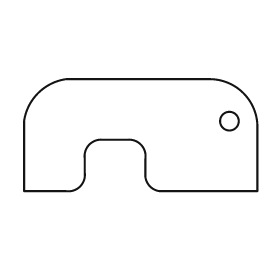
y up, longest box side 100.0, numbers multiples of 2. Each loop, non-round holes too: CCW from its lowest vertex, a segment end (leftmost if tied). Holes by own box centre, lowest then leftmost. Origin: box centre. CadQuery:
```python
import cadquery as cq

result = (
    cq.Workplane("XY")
    .moveTo(-50.0, -24.0)
    .lineTo(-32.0, -24.0)
    .threePointArc((-26.0, -22.0), (-24.0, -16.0))
    .lineTo(-24.0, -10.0)
    .threePointArc((-22.0, -4.0), (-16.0, -2.0))
    .lineTo(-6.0, -2.0)
    .threePointArc((0.0, -4.0), (2.0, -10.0))
    .lineTo(2.0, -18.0)
    .threePointArc((4.0, -22.0), (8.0, -24.0))
    .lineTo(50.0, -24.0)
    .lineTo(50.0, 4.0)
    .threePointArc((44.0, 18.0), (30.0, 24.0))
    .lineTo(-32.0, 24.0)
    .threePointArc((-44.0, 18.0), (-50.0, 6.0))
    .close()
    .moveTo(38.0, 6.0)
    .circle(4.0)
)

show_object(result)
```